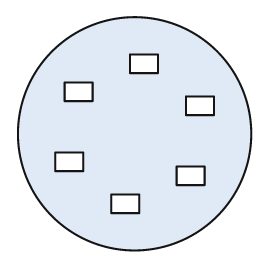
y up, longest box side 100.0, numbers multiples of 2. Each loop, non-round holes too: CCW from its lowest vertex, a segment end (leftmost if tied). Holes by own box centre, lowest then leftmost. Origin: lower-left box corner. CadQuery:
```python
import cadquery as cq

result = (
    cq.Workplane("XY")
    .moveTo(50.0, 50.0)
    .circle(50.0)
    .moveTo(40.0, 16.0)
    .lineTo(52.0, 16.0)
    .lineTo(52.0, 24.0)
    .lineTo(40.0, 24.0)
    .close()
    .moveTo(68.0, 28.0)
    .lineTo(80.0, 28.0)
    .lineTo(80.0, 36.0)
    .lineTo(68.0, 36.0)
    .close()
    .moveTo(16.0, 34.0)
    .lineTo(28.0, 34.0)
    .lineTo(28.0, 42.0)
    .lineTo(16.0, 42.0)
    .close()
    .moveTo(72.0, 58.0)
    .lineTo(84.0, 58.0)
    .lineTo(84.0, 66.0)
    .lineTo(72.0, 66.0)
    .close()
    .moveTo(20.0, 64.0)
    .lineTo(32.0, 64.0)
    .lineTo(32.0, 72.0)
    .lineTo(20.0, 72.0)
    .close()
    .moveTo(48.0, 76.0)
    .lineTo(60.0, 76.0)
    .lineTo(60.0, 84.0)
    .lineTo(48.0, 84.0)
    .close()
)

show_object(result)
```